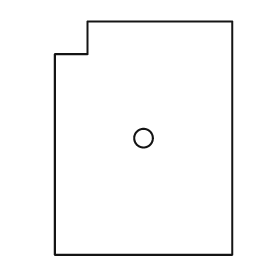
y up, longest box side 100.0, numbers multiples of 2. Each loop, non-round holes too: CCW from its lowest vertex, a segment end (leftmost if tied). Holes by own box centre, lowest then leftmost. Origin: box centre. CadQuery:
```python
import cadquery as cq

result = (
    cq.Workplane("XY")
    .moveTo(-38.0, -50.0)
    .lineTo(38.0, -50.0)
    .lineTo(38.0, 50.0)
    .lineTo(-24.0, 50.0)
    .lineTo(-24.0, 36.0)
    .lineTo(-38.0, 36.0)
    .close()
    .moveTo(0.0, 0.0)
    .circle(4.0)
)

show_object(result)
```